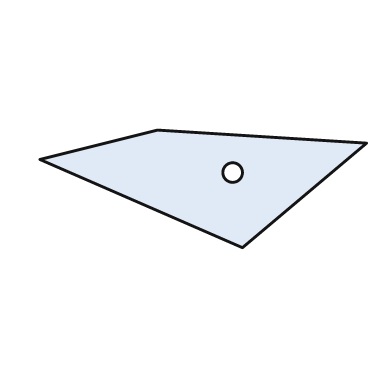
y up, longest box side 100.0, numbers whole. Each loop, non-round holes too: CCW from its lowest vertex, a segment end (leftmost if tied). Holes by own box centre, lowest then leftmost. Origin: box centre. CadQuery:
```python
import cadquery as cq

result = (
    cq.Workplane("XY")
    .moveTo(12.0, -18.0)
    .lineTo(50.0, 14.0)
    .lineTo(-14.0, 18.0)
    .lineTo(-50.0, 9.0)
    .close()
    .moveTo(9.0, 5.0)
    .circle(3.0)
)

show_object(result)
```